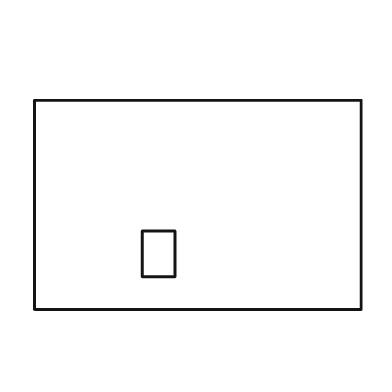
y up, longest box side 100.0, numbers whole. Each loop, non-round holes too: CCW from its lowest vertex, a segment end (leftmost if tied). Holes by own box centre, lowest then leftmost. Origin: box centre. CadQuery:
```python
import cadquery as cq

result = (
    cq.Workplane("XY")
    .moveTo(-50.0, -32.0)
    .lineTo(50.0, -32.0)
    .lineTo(50.0, 32.0)
    .lineTo(-50.0, 32.0)
    .close()
    .moveTo(-17.0, -22.0)
    .lineTo(-7.0, -22.0)
    .lineTo(-7.0, -8.0)
    .lineTo(-17.0, -8.0)
    .close()
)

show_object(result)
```